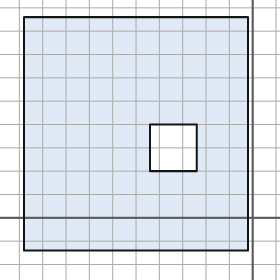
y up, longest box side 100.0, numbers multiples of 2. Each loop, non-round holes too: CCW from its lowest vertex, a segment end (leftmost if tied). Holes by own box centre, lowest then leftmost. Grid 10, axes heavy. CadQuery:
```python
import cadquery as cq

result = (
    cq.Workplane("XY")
    .moveTo(-98.0, -14.0)
    .lineTo(-2.0, -14.0)
    .lineTo(-2.0, 86.0)
    .lineTo(-98.0, 86.0)
    .close()
    .moveTo(-44.0, 20.0)
    .lineTo(-24.0, 20.0)
    .lineTo(-24.0, 40.0)
    .lineTo(-44.0, 40.0)
    .close()
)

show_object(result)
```